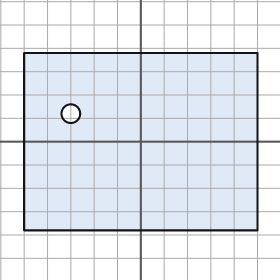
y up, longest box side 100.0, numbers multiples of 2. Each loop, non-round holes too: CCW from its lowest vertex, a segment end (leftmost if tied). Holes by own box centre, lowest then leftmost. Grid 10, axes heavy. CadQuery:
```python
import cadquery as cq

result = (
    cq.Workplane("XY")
    .moveTo(-50.0, -38.0)
    .lineTo(50.0, -38.0)
    .lineTo(50.0, 38.0)
    .lineTo(-50.0, 38.0)
    .close()
    .moveTo(-30.0, 12.0)
    .circle(4.0)
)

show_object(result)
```